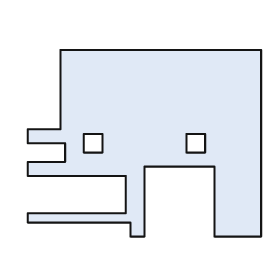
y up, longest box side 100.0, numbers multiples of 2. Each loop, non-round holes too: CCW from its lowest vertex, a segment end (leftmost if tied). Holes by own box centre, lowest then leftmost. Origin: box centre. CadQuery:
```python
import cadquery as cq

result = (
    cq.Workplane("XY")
    .moveTo(-6.0, -40.0)
    .lineTo(0.0, -40.0)
    .lineTo(0.0, -10.0)
    .lineTo(30.0, -10.0)
    .lineTo(30.0, -40.0)
    .lineTo(50.0, -40.0)
    .lineTo(50.0, 40.0)
    .lineTo(-36.0, 40.0)
    .lineTo(-36.0, 6.0)
    .lineTo(-50.0, 6.0)
    .lineTo(-50.0, 0.0)
    .lineTo(-34.0, 0.0)
    .lineTo(-34.0, -8.0)
    .lineTo(-50.0, -8.0)
    .lineTo(-50.0, -14.0)
    .lineTo(-8.0, -14.0)
    .lineTo(-8.0, -30.0)
    .lineTo(-50.0, -30.0)
    .lineTo(-50.0, -34.0)
    .lineTo(-6.0, -34.0)
    .close()
    .moveTo(-26.0, -4.0)
    .lineTo(-18.0, -4.0)
    .lineTo(-18.0, 4.0)
    .lineTo(-26.0, 4.0)
    .close()
    .moveTo(18.0, -4.0)
    .lineTo(26.0, -4.0)
    .lineTo(26.0, 4.0)
    .lineTo(18.0, 4.0)
    .close()
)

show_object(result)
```